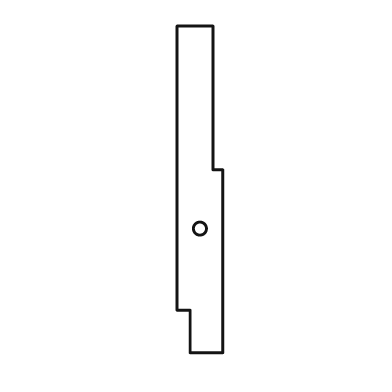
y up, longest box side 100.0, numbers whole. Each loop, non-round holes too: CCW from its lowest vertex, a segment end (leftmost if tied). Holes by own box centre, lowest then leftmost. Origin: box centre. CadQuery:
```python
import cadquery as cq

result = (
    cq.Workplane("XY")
    .moveTo(-3.0, -50.0)
    .lineTo(7.0, -50.0)
    .lineTo(7.0, 6.0)
    .lineTo(4.0, 6.0)
    .lineTo(4.0, 50.0)
    .lineTo(-7.0, 50.0)
    .lineTo(-7.0, -37.0)
    .lineTo(-3.0, -37.0)
    .close()
    .moveTo(0.0, -12.0)
    .circle(2.0)
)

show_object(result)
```